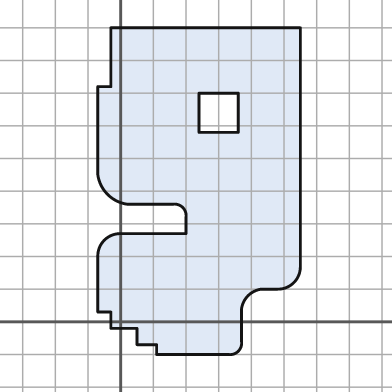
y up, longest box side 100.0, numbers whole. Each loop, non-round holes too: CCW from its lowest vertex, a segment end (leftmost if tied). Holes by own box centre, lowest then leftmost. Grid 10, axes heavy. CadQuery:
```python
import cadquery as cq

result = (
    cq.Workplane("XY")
    .moveTo(11.0, -10.0)
    .lineTo(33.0, -10.0)
    .threePointArc((36.0, -9.0), (37.0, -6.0))
    .lineTo(37.0, 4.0)
    .threePointArc((39.0, 8.0), (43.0, 10.0))
    .lineTo(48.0, 10.0)
    .threePointArc((53.0, 12.0), (55.0, 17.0))
    .lineTo(55.0, 90.0)
    .lineTo(-3.0, 90.0)
    .lineTo(-3.0, 72.0)
    .lineTo(-7.0, 72.0)
    .lineTo(-7.0, 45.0)
    .threePointArc((-4.0, 39.0), (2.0, 36.0))
    .lineTo(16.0, 36.0)
    .threePointArc((19.0, 35.0), (20.0, 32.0))
    .lineTo(20.0, 27.0)
    .lineTo(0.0, 27.0)
    .threePointArc((-5.0, 25.0), (-7.0, 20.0))
    .lineTo(-7.0, 3.0)
    .lineTo(-3.0, 3.0)
    .lineTo(-3.0, -2.0)
    .lineTo(5.0, -2.0)
    .lineTo(5.0, -7.0)
    .lineTo(11.0, -7.0)
    .close()
    .moveTo(24.0, 58.0)
    .lineTo(36.0, 58.0)
    .lineTo(36.0, 70.0)
    .lineTo(24.0, 70.0)
    .close()
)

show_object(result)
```